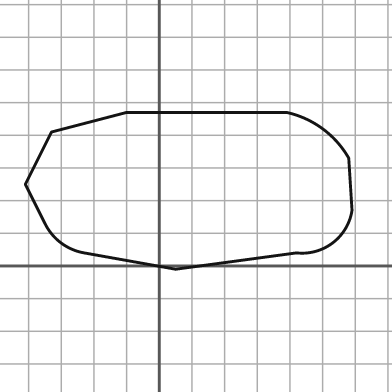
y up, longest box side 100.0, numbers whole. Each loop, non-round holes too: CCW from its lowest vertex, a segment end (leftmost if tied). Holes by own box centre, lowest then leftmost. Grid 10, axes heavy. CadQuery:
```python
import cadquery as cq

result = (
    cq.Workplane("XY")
    .moveTo(5.0, -1.0)
    .lineTo(42.0, 4.0)
    .threePointArc((53.0, 7.0), (59.0, 17.0))
    .lineTo(58.0, 33.0)
    .threePointArc((50.0, 42.0), (39.0, 47.0))
    .lineTo(-10.0, 47.0)
    .lineTo(-33.0, 41.0)
    .lineTo(-41.0, 25.0)
    .lineTo(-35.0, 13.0)
    .threePointArc((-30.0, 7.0), (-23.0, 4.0))
    .close()
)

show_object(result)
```